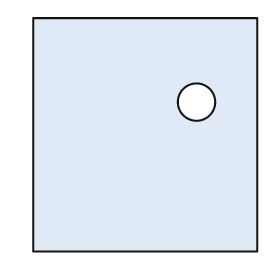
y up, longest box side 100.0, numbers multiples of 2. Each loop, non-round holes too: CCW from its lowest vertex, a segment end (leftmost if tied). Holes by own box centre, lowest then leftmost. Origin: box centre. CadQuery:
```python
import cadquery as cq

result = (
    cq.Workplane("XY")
    .moveTo(-48.0, -50.0)
    .lineTo(48.0, -50.0)
    .lineTo(48.0, 50.0)
    .lineTo(-48.0, 50.0)
    .close()
    .moveTo(22.0, 14.0)
    .circle(8.0)
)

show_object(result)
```